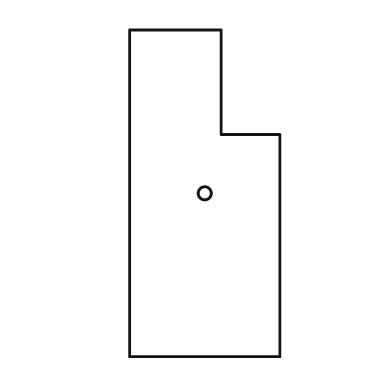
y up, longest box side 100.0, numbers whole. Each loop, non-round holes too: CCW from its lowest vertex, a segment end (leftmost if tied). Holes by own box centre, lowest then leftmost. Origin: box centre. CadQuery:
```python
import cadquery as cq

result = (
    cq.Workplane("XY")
    .moveTo(-23.0, -50.0)
    .lineTo(23.0, -50.0)
    .lineTo(23.0, 18.0)
    .lineTo(5.0, 18.0)
    .lineTo(5.0, 50.0)
    .lineTo(-23.0, 50.0)
    .close()
    .moveTo(0.0, 0.0)
    .circle(2.0)
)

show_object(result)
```